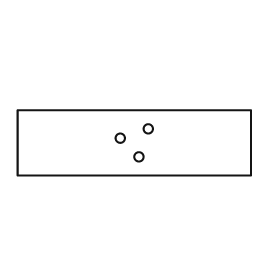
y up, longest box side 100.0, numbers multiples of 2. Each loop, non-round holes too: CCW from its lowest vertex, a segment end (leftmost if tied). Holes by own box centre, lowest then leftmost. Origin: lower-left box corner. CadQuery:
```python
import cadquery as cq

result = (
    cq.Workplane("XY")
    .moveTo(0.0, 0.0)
    .lineTo(100.0, 0.0)
    .lineTo(100.0, 28.0)
    .lineTo(0.0, 28.0)
    .close()
    .moveTo(52.0, 8.0)
    .circle(2.0)
    .moveTo(44.0, 16.0)
    .circle(2.0)
    .moveTo(56.0, 20.0)
    .circle(2.0)
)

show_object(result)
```